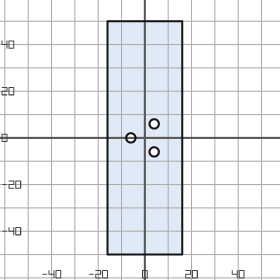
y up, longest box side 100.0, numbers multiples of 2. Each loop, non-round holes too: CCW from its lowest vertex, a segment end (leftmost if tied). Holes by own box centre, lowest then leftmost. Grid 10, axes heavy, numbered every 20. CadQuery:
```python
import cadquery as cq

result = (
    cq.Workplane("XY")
    .moveTo(-16.0, -50.0)
    .lineTo(16.0, -50.0)
    .lineTo(16.0, 50.0)
    .lineTo(-16.0, 50.0)
    .close()
    .moveTo(4.0, -6.0)
    .circle(2.0)
    .moveTo(-6.0, 0.0)
    .circle(2.0)
    .moveTo(4.0, 6.0)
    .circle(2.0)
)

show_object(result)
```